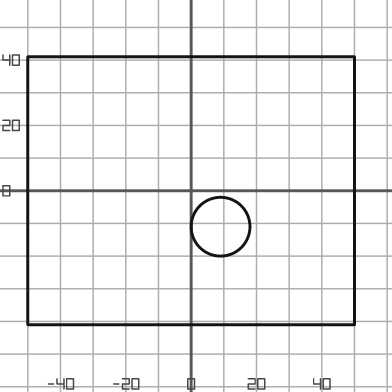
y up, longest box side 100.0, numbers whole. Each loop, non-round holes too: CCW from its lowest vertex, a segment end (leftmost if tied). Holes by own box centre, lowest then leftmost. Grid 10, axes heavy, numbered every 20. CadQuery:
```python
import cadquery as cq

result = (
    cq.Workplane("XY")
    .moveTo(-50.0, -41.0)
    .lineTo(50.0, -41.0)
    .lineTo(50.0, 41.0)
    .lineTo(-50.0, 41.0)
    .close()
    .moveTo(9.0, -11.0)
    .circle(9.0)
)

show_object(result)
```